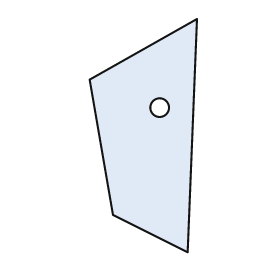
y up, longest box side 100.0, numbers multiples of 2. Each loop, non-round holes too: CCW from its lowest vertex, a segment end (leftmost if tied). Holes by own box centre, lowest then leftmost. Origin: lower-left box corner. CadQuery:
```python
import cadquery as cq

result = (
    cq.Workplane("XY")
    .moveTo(42.0, 0.0)
    .lineTo(46.0, 100.0)
    .lineTo(0.0, 74.0)
    .lineTo(10.0, 16.0)
    .close()
    .moveTo(30.0, 62.0)
    .circle(4.0)
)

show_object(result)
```